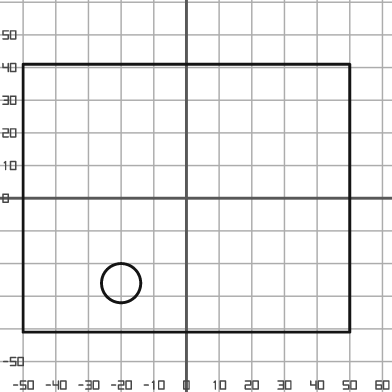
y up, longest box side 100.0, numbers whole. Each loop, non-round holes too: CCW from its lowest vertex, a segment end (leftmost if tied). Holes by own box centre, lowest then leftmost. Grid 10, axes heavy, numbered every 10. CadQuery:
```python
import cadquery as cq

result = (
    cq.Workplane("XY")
    .moveTo(-50.0, -41.0)
    .lineTo(50.0, -41.0)
    .lineTo(50.0, 41.0)
    .lineTo(-50.0, 41.0)
    .close()
    .moveTo(-20.0, -26.0)
    .circle(6.0)
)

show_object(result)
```